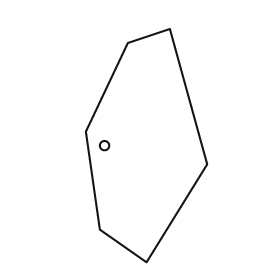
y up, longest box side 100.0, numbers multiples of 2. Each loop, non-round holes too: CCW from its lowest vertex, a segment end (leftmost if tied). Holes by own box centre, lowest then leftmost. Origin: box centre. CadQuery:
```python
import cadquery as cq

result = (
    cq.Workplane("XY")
    .moveTo(0.0, -50.0)
    .lineTo(26.0, -8.0)
    .lineTo(10.0, 50.0)
    .lineTo(-8.0, 44.0)
    .lineTo(-26.0, 6.0)
    .lineTo(-20.0, -36.0)
    .close()
    .moveTo(-18.0, 0.0)
    .circle(2.0)
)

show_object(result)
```